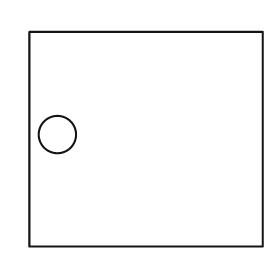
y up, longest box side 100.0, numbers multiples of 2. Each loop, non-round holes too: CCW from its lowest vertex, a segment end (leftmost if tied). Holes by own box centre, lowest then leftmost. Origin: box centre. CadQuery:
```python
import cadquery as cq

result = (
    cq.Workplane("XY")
    .moveTo(-50.0, -46.0)
    .lineTo(50.0, -46.0)
    .lineTo(50.0, 46.0)
    .lineTo(-50.0, 46.0)
    .close()
    .moveTo(-38.0, 2.0)
    .circle(8.0)
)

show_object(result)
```